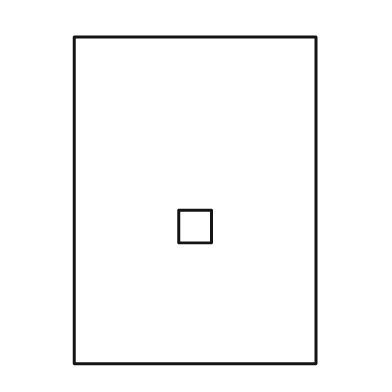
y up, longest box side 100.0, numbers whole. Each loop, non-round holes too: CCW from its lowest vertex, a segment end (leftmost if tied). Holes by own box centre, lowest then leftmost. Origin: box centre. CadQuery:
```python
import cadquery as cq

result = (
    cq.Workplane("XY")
    .moveTo(-37.0, -50.0)
    .lineTo(37.0, -50.0)
    .lineTo(37.0, 50.0)
    .lineTo(-37.0, 50.0)
    .close()
    .moveTo(-5.0, -13.0)
    .lineTo(5.0, -13.0)
    .lineTo(5.0, -3.0)
    .lineTo(-5.0, -3.0)
    .close()
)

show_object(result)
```